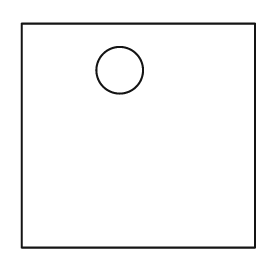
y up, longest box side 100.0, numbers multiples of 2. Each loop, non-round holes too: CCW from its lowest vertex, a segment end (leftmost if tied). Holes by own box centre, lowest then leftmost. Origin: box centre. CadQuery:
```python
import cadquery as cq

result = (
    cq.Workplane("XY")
    .moveTo(-50.0, -48.0)
    .lineTo(50.0, -48.0)
    .lineTo(50.0, 48.0)
    .lineTo(-50.0, 48.0)
    .close()
    .moveTo(-8.0, 28.0)
    .circle(10.0)
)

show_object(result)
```